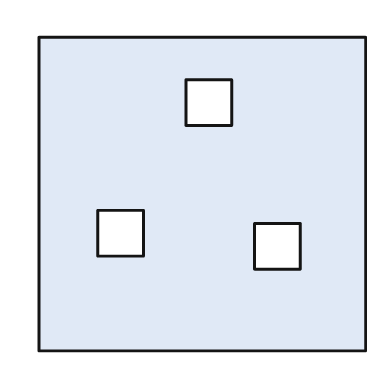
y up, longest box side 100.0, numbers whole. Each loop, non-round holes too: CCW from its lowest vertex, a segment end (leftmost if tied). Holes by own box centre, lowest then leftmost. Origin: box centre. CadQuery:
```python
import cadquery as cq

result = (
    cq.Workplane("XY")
    .moveTo(-50.0, -48.0)
    .lineTo(50.0, -48.0)
    .lineTo(50.0, 48.0)
    .lineTo(-50.0, 48.0)
    .close()
    .moveTo(16.0, -23.0)
    .lineTo(30.0, -23.0)
    .lineTo(30.0, -9.0)
    .lineTo(16.0, -9.0)
    .close()
    .moveTo(-32.0, -19.0)
    .lineTo(-18.0, -19.0)
    .lineTo(-18.0, -5.0)
    .lineTo(-32.0, -5.0)
    .close()
    .moveTo(-5.0, 21.0)
    .lineTo(9.0, 21.0)
    .lineTo(9.0, 35.0)
    .lineTo(-5.0, 35.0)
    .close()
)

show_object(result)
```